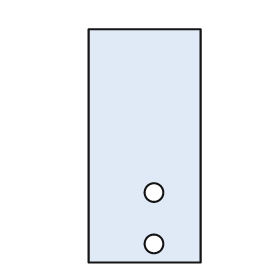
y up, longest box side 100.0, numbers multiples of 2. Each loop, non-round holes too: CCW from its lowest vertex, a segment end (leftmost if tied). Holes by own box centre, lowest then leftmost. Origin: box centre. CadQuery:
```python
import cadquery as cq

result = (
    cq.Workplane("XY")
    .moveTo(-24.0, -50.0)
    .lineTo(24.0, -50.0)
    .lineTo(24.0, 50.0)
    .lineTo(-24.0, 50.0)
    .close()
    .moveTo(4.0, -42.0)
    .circle(4.0)
    .moveTo(4.0, -20.0)
    .circle(4.0)
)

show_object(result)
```